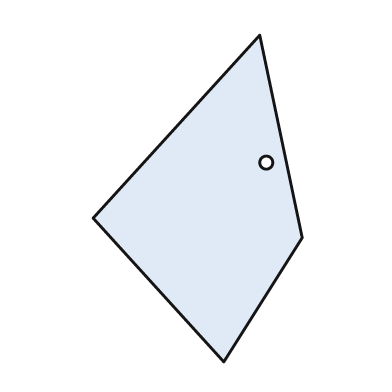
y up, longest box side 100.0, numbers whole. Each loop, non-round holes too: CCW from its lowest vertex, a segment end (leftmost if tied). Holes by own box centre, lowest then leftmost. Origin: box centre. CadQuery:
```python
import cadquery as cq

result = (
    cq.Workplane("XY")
    .moveTo(8.0, -50.0)
    .lineTo(32.0, -12.0)
    .lineTo(19.0, 50.0)
    .lineTo(-32.0, -6.0)
    .close()
    .moveTo(21.0, 11.0)
    .circle(2.0)
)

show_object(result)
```